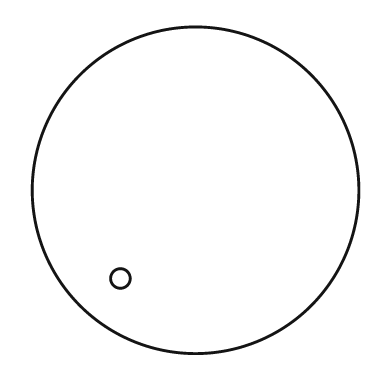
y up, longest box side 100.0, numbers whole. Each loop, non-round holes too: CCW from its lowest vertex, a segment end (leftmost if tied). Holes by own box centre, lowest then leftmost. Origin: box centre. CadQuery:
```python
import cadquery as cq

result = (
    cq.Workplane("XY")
    .moveTo(0.0, 0.0)
    .circle(50.0)
    .moveTo(-23.0, -27.0)
    .circle(3.0)
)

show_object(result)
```